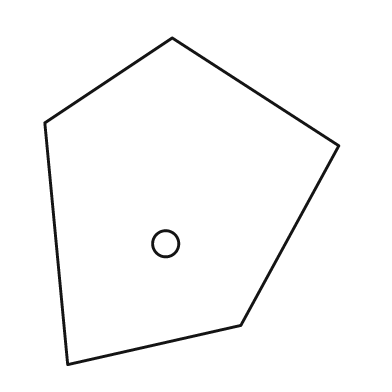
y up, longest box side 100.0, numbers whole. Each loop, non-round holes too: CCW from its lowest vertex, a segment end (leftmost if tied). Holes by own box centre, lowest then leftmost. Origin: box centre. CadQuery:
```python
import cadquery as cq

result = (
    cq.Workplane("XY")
    .moveTo(-38.0, -50.0)
    .lineTo(15.0, -38.0)
    .lineTo(45.0, 17.0)
    .lineTo(-6.0, 50.0)
    .lineTo(-45.0, 24.0)
    .close()
    .moveTo(-8.0, -13.0)
    .circle(4.0)
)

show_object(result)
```